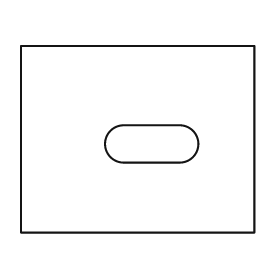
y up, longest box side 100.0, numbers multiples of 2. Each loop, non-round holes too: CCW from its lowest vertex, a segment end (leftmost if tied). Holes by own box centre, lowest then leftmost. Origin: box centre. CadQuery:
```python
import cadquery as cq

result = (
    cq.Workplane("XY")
    .moveTo(-50.0, -40.0)
    .lineTo(50.0, -40.0)
    .lineTo(50.0, 40.0)
    .lineTo(-50.0, 40.0)
    .close()
    .moveTo(-6.0, -10.0)
    .lineTo(18.0, -10.0)
    .threePointArc((26.0, -2.0), (18.0, 6.0))
    .lineTo(-6.0, 6.0)
    .threePointArc((-14.0, -2.0), (-6.0, -10.0))
    .close()
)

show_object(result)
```